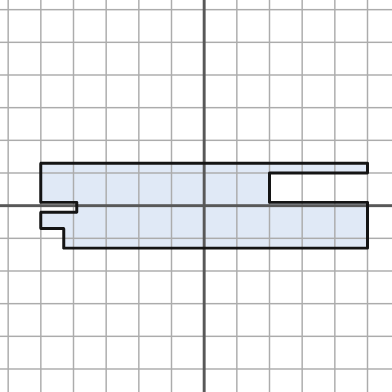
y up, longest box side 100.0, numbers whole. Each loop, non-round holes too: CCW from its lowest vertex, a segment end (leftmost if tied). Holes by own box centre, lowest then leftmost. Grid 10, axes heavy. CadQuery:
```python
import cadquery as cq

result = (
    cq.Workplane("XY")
    .moveTo(-43.0, -13.0)
    .lineTo(50.0, -13.0)
    .lineTo(50.0, 1.0)
    .lineTo(20.0, 1.0)
    .lineTo(20.0, 10.0)
    .lineTo(50.0, 10.0)
    .lineTo(50.0, 13.0)
    .lineTo(-50.0, 13.0)
    .lineTo(-50.0, 1.0)
    .lineTo(-39.0, 1.0)
    .lineTo(-39.0, -2.0)
    .lineTo(-50.0, -2.0)
    .lineTo(-50.0, -7.0)
    .lineTo(-43.0, -7.0)
    .close()
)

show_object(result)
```